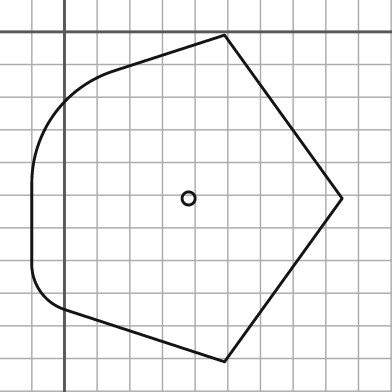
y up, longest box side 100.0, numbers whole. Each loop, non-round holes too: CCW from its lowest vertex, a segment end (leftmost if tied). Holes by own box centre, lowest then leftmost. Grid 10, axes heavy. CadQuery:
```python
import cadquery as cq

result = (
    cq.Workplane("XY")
    .moveTo(49.0, -101.0)
    .lineTo(85.0, -51.0)
    .lineTo(49.0, -1.0)
    .lineTo(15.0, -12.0)
    .threePointArc((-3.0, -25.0), (-10.0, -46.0))
    .lineTo(-10.0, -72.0)
    .threePointArc((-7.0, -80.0), (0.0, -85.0))
    .close()
    .moveTo(38.0, -51.0)
    .circle(2.0)
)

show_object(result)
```